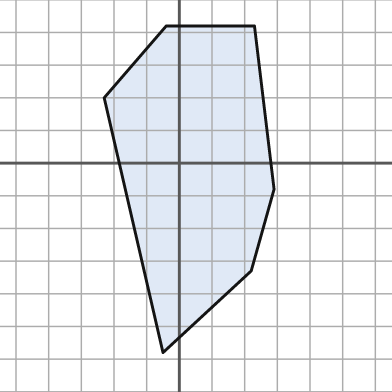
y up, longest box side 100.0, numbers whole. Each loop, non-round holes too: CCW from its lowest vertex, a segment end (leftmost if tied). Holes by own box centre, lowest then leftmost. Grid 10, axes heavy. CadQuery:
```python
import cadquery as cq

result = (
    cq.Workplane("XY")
    .moveTo(-5.0, -58.0)
    .lineTo(22.0, -33.0)
    .lineTo(29.0, -8.0)
    .lineTo(23.0, 42.0)
    .lineTo(-4.0, 42.0)
    .lineTo(-23.0, 20.0)
    .close()
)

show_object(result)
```